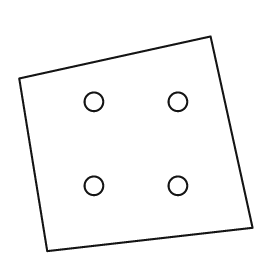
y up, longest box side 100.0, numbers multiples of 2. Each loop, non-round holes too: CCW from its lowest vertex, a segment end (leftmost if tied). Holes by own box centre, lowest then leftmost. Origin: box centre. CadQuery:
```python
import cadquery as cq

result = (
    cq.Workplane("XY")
    .moveTo(-38.0, -46.0)
    .lineTo(50.0, -36.0)
    .lineTo(32.0, 46.0)
    .lineTo(-50.0, 28.0)
    .close()
    .moveTo(-18.0, -18.0)
    .circle(4.0)
    .moveTo(18.0, -18.0)
    .circle(4.0)
    .moveTo(-18.0, 18.0)
    .circle(4.0)
    .moveTo(18.0, 18.0)
    .circle(4.0)
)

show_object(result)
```